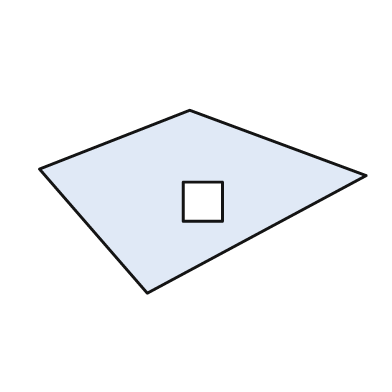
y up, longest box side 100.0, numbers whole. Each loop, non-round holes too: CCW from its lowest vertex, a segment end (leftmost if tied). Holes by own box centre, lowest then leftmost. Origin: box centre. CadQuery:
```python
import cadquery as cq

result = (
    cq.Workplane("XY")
    .moveTo(-17.0, -28.0)
    .lineTo(50.0, 8.0)
    .lineTo(-4.0, 28.0)
    .lineTo(-50.0, 10.0)
    .close()
    .moveTo(-6.0, -6.0)
    .lineTo(6.0, -6.0)
    .lineTo(6.0, 6.0)
    .lineTo(-6.0, 6.0)
    .close()
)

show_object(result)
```